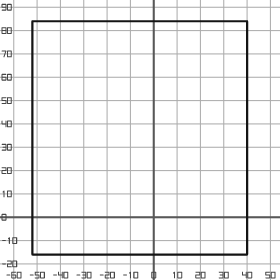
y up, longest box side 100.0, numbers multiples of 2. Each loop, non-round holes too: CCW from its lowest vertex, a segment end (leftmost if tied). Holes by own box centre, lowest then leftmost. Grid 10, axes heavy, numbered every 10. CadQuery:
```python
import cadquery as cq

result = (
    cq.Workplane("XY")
    .moveTo(-52.0, -16.0)
    .lineTo(40.0, -16.0)
    .lineTo(40.0, 84.0)
    .lineTo(-52.0, 84.0)
    .close()
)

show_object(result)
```